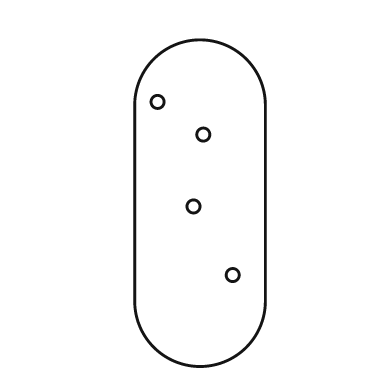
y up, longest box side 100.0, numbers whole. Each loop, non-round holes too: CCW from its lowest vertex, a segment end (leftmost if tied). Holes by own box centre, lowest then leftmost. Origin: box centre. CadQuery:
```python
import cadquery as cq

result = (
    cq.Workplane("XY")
    .moveTo(-20.0, -30.0)
    .threePointArc((0.0, -50.0), (20.0, -30.0))
    .lineTo(20.0, 30.0)
    .threePointArc((0.0, 50.0), (-20.0, 30.0))
    .close()
    .moveTo(10.0, -22.0)
    .circle(2.0)
    .moveTo(-2.0, -1.0)
    .circle(2.0)
    .moveTo(1.0, 21.0)
    .circle(2.0)
    .moveTo(-13.0, 31.0)
    .circle(2.0)
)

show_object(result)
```